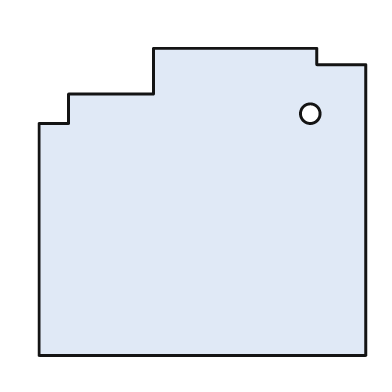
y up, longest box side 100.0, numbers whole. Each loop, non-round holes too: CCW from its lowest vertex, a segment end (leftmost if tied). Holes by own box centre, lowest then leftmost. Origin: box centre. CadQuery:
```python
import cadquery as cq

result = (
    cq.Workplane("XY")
    .moveTo(-50.0, -47.0)
    .lineTo(50.0, -47.0)
    .lineTo(50.0, 42.0)
    .lineTo(35.0, 42.0)
    .lineTo(35.0, 47.0)
    .lineTo(-15.0, 47.0)
    .lineTo(-15.0, 33.0)
    .lineTo(-41.0, 33.0)
    .lineTo(-41.0, 24.0)
    .lineTo(-50.0, 24.0)
    .close()
    .moveTo(33.0, 27.0)
    .circle(3.0)
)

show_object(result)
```